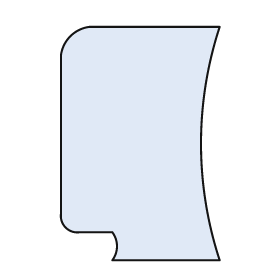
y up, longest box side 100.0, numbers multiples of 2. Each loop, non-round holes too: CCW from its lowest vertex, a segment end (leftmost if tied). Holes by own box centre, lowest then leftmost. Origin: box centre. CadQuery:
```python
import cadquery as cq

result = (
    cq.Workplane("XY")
    .moveTo(-12.0, -50.0)
    .lineTo(34.0, -50.0)
    .threePointArc((26.0, 0.0), (34.0, 50.0))
    .lineTo(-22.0, 50.0)
    .threePointArc((-30.0, 46.0), (-34.0, 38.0))
    .lineTo(-34.0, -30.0)
    .threePointArc((-32.0, -36.0), (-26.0, -38.0))
    .lineTo(-12.0, -38.0)
    .threePointArc((-10.0, -44.0), (-12.0, -50.0))
    .close()
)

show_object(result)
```